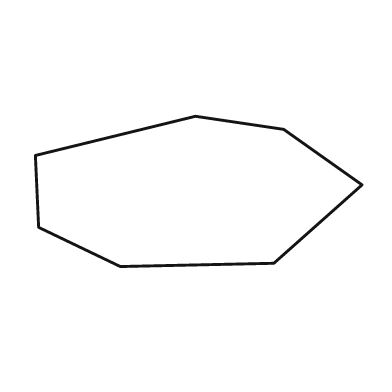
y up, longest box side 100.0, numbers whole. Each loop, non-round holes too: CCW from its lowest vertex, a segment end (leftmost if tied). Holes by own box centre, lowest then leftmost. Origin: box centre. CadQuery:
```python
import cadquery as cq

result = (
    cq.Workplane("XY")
    .moveTo(-24.0, -23.0)
    .lineTo(23.0, -22.0)
    .lineTo(50.0, 2.0)
    .lineTo(26.0, 19.0)
    .lineTo(-1.0, 23.0)
    .lineTo(-50.0, 11.0)
    .lineTo(-49.0, -11.0)
    .close()
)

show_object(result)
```